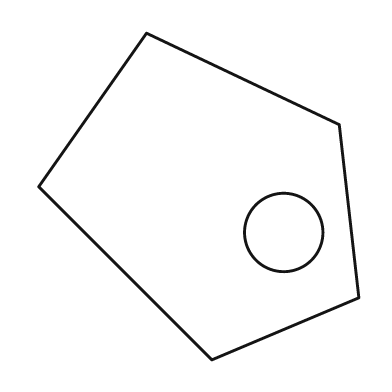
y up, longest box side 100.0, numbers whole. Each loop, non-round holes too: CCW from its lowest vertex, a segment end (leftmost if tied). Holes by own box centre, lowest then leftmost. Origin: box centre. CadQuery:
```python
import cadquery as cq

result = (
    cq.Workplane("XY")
    .moveTo(4.0, -50.0)
    .lineTo(49.0, -31.0)
    .lineTo(43.0, 22.0)
    .lineTo(-16.0, 50.0)
    .lineTo(-49.0, 3.0)
    .close()
    .moveTo(26.0, -11.0)
    .circle(12.0)
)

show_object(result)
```